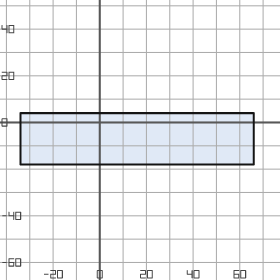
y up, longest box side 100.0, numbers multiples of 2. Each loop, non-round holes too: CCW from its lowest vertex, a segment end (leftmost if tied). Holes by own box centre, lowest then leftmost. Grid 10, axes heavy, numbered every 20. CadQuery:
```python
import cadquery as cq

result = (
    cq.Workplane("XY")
    .moveTo(-34.0, -18.0)
    .lineTo(66.0, -18.0)
    .lineTo(66.0, 4.0)
    .lineTo(-34.0, 4.0)
    .close()
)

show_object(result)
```